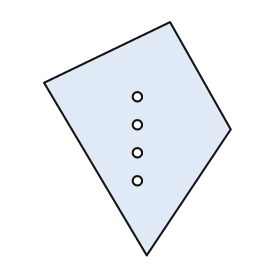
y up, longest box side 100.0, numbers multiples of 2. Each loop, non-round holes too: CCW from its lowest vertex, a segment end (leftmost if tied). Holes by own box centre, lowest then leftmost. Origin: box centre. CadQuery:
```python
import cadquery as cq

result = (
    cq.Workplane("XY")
    .moveTo(4.0, -50.0)
    .lineTo(40.0, 4.0)
    .lineTo(14.0, 50.0)
    .lineTo(-40.0, 24.0)
    .close()
    .moveTo(0.0, -18.0)
    .circle(2.0)
    .moveTo(0.0, -6.0)
    .circle(2.0)
    .moveTo(0.0, 6.0)
    .circle(2.0)
    .moveTo(0.0, 18.0)
    .circle(2.0)
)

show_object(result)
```